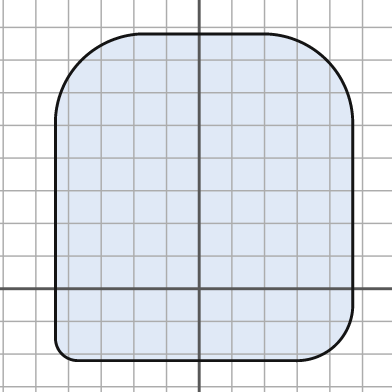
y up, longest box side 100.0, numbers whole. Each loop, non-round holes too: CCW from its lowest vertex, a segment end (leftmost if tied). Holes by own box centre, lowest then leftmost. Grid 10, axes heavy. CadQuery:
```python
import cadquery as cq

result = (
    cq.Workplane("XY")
    .moveTo(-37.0, -22.0)
    .lineTo(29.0, -22.0)
    .threePointArc((42.0, -17.0), (47.0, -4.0))
    .lineTo(47.0, 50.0)
    .threePointArc((39.0, 70.0), (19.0, 78.0))
    .lineTo(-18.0, 78.0)
    .threePointArc((-36.0, 70.0), (-44.0, 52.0))
    .lineTo(-44.0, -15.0)
    .threePointArc((-42.0, -20.0), (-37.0, -22.0))
    .close()
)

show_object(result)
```